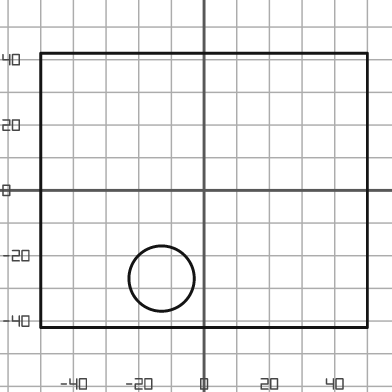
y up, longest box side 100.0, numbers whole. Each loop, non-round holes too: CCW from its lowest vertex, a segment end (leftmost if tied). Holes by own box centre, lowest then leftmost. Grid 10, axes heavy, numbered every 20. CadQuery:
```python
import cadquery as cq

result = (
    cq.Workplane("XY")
    .moveTo(-50.0, -42.0)
    .lineTo(50.0, -42.0)
    .lineTo(50.0, 42.0)
    .lineTo(-50.0, 42.0)
    .close()
    .moveTo(-13.0, -27.0)
    .circle(10.0)
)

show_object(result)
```